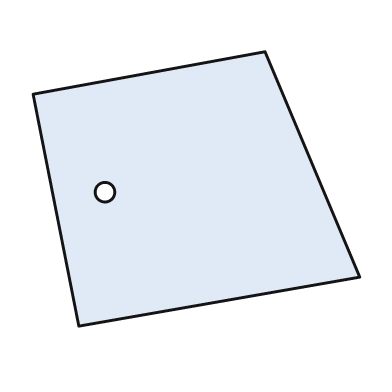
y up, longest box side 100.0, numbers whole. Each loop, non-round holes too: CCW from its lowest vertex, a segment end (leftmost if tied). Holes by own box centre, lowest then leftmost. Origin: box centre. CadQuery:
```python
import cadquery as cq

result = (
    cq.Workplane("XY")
    .moveTo(-36.0, -42.0)
    .lineTo(50.0, -27.0)
    .lineTo(21.0, 42.0)
    .lineTo(-50.0, 29.0)
    .close()
    .moveTo(-28.0, -1.0)
    .circle(3.0)
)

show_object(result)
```